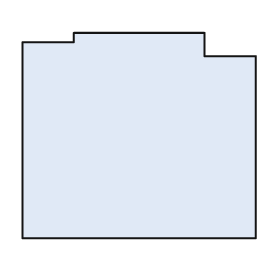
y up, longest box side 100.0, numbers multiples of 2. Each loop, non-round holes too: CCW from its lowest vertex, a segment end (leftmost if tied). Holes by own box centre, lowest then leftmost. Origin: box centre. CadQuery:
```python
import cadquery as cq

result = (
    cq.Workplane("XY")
    .moveTo(-50.0, -44.0)
    .lineTo(50.0, -44.0)
    .lineTo(50.0, 34.0)
    .lineTo(28.0, 34.0)
    .lineTo(28.0, 44.0)
    .lineTo(-28.0, 44.0)
    .lineTo(-28.0, 40.0)
    .lineTo(-50.0, 40.0)
    .close()
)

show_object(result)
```